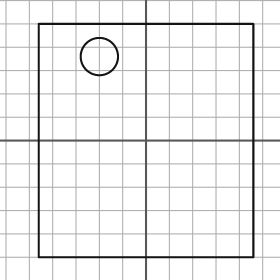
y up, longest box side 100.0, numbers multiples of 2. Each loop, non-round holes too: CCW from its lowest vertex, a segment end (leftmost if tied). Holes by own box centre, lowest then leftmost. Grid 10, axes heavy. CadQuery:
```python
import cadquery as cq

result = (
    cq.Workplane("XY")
    .moveTo(-46.0, -50.0)
    .lineTo(46.0, -50.0)
    .lineTo(46.0, 50.0)
    .lineTo(-46.0, 50.0)
    .close()
    .moveTo(-20.0, 36.0)
    .circle(8.0)
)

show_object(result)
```